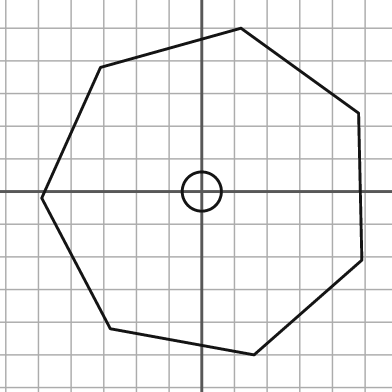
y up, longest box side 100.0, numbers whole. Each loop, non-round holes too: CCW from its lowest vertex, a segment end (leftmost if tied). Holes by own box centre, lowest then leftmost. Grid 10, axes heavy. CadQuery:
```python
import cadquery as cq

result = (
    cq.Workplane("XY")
    .moveTo(16.0, -50.0)
    .lineTo(49.0, -21.0)
    .lineTo(48.0, 24.0)
    .lineTo(12.0, 50.0)
    .lineTo(-31.0, 38.0)
    .lineTo(-49.0, -2.0)
    .lineTo(-28.0, -42.0)
    .close()
    .moveTo(0.0, 0.0)
    .circle(6.0)
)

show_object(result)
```